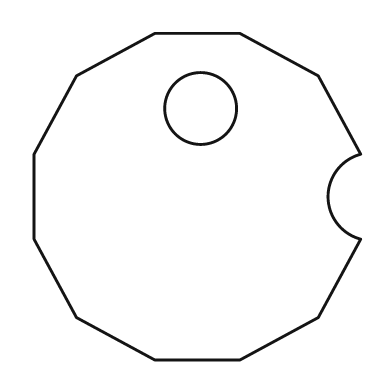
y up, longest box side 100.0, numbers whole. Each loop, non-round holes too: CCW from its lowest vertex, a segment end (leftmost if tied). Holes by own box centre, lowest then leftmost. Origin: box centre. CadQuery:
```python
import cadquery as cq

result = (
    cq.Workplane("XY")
    .moveTo(-13.0, -50.0)
    .lineTo(13.0, -50.0)
    .lineTo(37.0, -37.0)
    .lineTo(50.0, -13.0)
    .threePointArc((40.0, 0.0), (50.0, 13.0))
    .lineTo(37.0, 37.0)
    .lineTo(13.0, 50.0)
    .lineTo(-13.0, 50.0)
    .lineTo(-37.0, 37.0)
    .lineTo(-50.0, 13.0)
    .lineTo(-50.0, -13.0)
    .lineTo(-37.0, -37.0)
    .close()
    .moveTo(1.0, 27.0)
    .circle(11.0)
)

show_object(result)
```